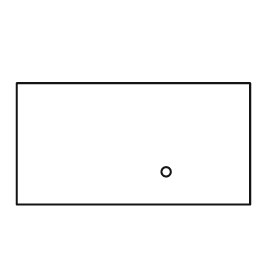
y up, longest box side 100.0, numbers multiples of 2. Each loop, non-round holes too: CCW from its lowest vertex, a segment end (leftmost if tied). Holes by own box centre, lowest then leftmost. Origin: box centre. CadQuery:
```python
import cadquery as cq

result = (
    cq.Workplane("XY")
    .moveTo(-50.0, -26.0)
    .lineTo(50.0, -26.0)
    .lineTo(50.0, 26.0)
    .lineTo(-50.0, 26.0)
    .close()
    .moveTo(14.0, -12.0)
    .circle(2.0)
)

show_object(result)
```